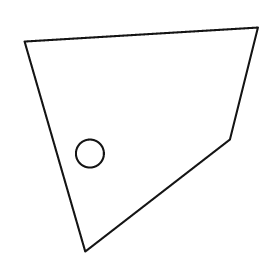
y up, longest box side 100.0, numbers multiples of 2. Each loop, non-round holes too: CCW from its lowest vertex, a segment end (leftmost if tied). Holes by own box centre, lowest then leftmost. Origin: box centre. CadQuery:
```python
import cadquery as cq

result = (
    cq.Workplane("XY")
    .moveTo(-24.0, -48.0)
    .lineTo(38.0, 0.0)
    .lineTo(50.0, 48.0)
    .lineTo(-50.0, 42.0)
    .close()
    .moveTo(-22.0, -6.0)
    .circle(6.0)
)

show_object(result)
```